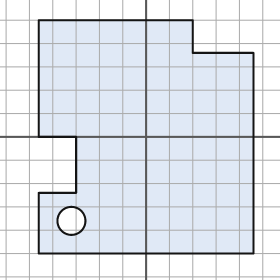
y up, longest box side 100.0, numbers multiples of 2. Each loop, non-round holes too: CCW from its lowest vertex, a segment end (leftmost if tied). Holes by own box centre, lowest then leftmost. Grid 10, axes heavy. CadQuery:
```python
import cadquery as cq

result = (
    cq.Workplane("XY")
    .moveTo(-46.0, -50.0)
    .lineTo(46.0, -50.0)
    .lineTo(46.0, 36.0)
    .lineTo(20.0, 36.0)
    .lineTo(20.0, 50.0)
    .lineTo(-46.0, 50.0)
    .lineTo(-46.0, 0.0)
    .lineTo(-30.0, 0.0)
    .lineTo(-30.0, -24.0)
    .lineTo(-46.0, -24.0)
    .close()
    .moveTo(-32.0, -36.0)
    .circle(6.0)
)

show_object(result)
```